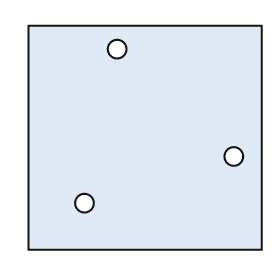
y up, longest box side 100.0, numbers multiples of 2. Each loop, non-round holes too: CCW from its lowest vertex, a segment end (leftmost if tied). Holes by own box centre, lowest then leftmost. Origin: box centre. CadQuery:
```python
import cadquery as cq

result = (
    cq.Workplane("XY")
    .moveTo(-50.0, -48.0)
    .lineTo(50.0, -48.0)
    .lineTo(50.0, 48.0)
    .lineTo(-50.0, 48.0)
    .close()
    .moveTo(-26.0, -28.0)
    .circle(4.0)
    .moveTo(38.0, -8.0)
    .circle(4.0)
    .moveTo(-12.0, 38.0)
    .circle(4.0)
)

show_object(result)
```